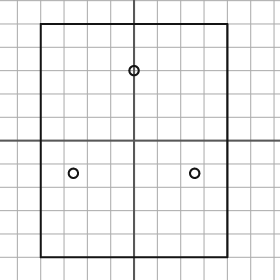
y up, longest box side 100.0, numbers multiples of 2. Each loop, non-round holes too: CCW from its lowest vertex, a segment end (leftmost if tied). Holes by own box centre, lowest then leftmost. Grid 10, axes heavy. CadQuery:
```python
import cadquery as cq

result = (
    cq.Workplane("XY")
    .moveTo(-40.0, -50.0)
    .lineTo(40.0, -50.0)
    .lineTo(40.0, 50.0)
    .lineTo(-40.0, 50.0)
    .close()
    .moveTo(-26.0, -14.0)
    .circle(2.0)
    .moveTo(26.0, -14.0)
    .circle(2.0)
    .moveTo(0.0, 30.0)
    .circle(2.0)
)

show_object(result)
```